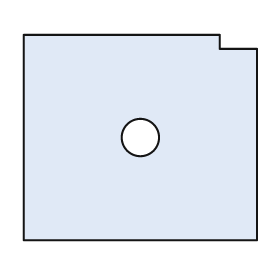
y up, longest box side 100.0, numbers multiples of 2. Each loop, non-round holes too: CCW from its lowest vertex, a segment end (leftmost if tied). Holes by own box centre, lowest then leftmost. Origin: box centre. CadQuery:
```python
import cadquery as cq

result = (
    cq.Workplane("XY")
    .moveTo(-50.0, -44.0)
    .lineTo(50.0, -44.0)
    .lineTo(50.0, 38.0)
    .lineTo(34.0, 38.0)
    .lineTo(34.0, 44.0)
    .lineTo(-50.0, 44.0)
    .close()
    .moveTo(0.0, 0.0)
    .circle(8.0)
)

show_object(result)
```